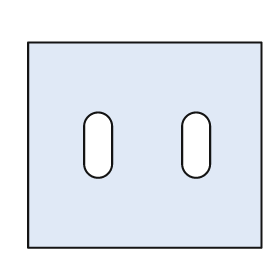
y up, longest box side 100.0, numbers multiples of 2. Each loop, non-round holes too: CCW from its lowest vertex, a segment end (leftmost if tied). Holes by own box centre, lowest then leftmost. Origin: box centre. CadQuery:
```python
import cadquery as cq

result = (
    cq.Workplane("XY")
    .moveTo(-50.0, -44.0)
    .lineTo(50.0, -44.0)
    .lineTo(50.0, 44.0)
    .lineTo(-50.0, 44.0)
    .close()
    .moveTo(-26.0, -8.0)
    .threePointArc((-20.0, -14.0), (-14.0, -8.0))
    .lineTo(-14.0, 8.0)
    .threePointArc((-20.0, 14.0), (-26.0, 8.0))
    .close()
    .moveTo(16.0, -8.0)
    .threePointArc((22.0, -14.0), (28.0, -8.0))
    .lineTo(28.0, 8.0)
    .threePointArc((22.0, 14.0), (16.0, 8.0))
    .close()
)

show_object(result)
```